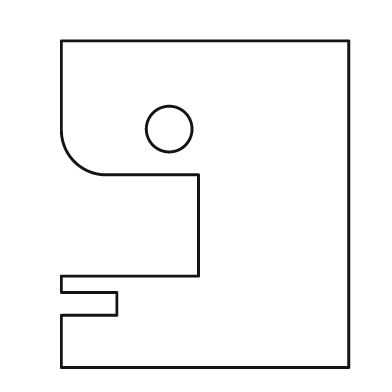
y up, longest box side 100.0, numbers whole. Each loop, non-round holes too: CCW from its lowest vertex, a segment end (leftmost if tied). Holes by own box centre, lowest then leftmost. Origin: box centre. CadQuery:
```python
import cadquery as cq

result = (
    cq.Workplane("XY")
    .moveTo(-44.0, -50.0)
    .lineTo(44.0, -50.0)
    .lineTo(44.0, 50.0)
    .lineTo(-44.0, 50.0)
    .lineTo(-44.0, 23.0)
    .threePointArc((-40.0, 13.0), (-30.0, 9.0))
    .lineTo(-2.0, 9.0)
    .lineTo(-2.0, -22.0)
    .lineTo(-44.0, -22.0)
    .lineTo(-44.0, -27.0)
    .lineTo(-27.0, -27.0)
    .lineTo(-27.0, -34.0)
    .lineTo(-44.0, -34.0)
    .close()
    .moveTo(-11.0, 23.0)
    .circle(7.0)
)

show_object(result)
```